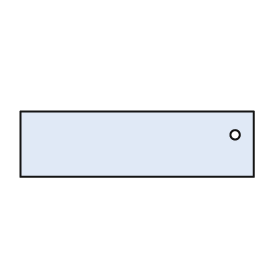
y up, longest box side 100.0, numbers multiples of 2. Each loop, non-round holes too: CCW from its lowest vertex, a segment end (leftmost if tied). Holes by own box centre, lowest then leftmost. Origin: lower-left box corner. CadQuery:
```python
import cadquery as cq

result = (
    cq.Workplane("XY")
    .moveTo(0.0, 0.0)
    .lineTo(100.0, 0.0)
    .lineTo(100.0, 28.0)
    .lineTo(0.0, 28.0)
    .close()
    .moveTo(92.0, 18.0)
    .circle(2.0)
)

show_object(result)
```